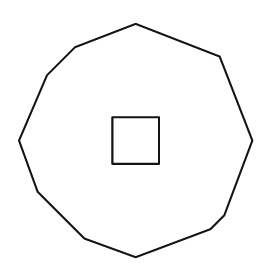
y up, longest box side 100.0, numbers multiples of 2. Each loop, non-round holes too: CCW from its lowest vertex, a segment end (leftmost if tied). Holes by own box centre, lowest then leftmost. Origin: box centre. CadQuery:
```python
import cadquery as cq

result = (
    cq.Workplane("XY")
    .moveTo(0.0, -50.0)
    .lineTo(32.0, -38.0)
    .lineTo(38.0, -32.0)
    .lineTo(50.0, 0.0)
    .lineTo(36.0, 36.0)
    .lineTo(0.0, 50.0)
    .lineTo(-26.0, 40.0)
    .lineTo(-38.0, 28.0)
    .lineTo(-50.0, 0.0)
    .lineTo(-42.0, -22.0)
    .lineTo(-22.0, -42.0)
    .close()
    .moveTo(-10.0, -10.0)
    .lineTo(10.0, -10.0)
    .lineTo(10.0, 10.0)
    .lineTo(-10.0, 10.0)
    .close()
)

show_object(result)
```